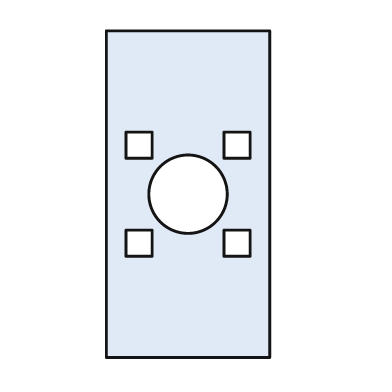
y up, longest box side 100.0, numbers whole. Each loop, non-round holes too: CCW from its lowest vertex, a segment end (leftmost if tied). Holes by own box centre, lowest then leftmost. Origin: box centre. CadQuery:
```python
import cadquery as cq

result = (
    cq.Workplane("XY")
    .moveTo(-25.0, -50.0)
    .lineTo(25.0, -50.0)
    .lineTo(25.0, 50.0)
    .lineTo(-25.0, 50.0)
    .close()
    .moveTo(-19.0, -19.0)
    .lineTo(-11.0, -19.0)
    .lineTo(-11.0, -11.0)
    .lineTo(-19.0, -11.0)
    .close()
    .moveTo(11.0, -19.0)
    .lineTo(19.0, -19.0)
    .lineTo(19.0, -11.0)
    .lineTo(11.0, -11.0)
    .close()
    .moveTo(0.0, 0.0)
    .circle(12.0)
    .moveTo(-19.0, 11.0)
    .lineTo(-11.0, 11.0)
    .lineTo(-11.0, 19.0)
    .lineTo(-19.0, 19.0)
    .close()
    .moveTo(11.0, 11.0)
    .lineTo(19.0, 11.0)
    .lineTo(19.0, 19.0)
    .lineTo(11.0, 19.0)
    .close()
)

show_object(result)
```